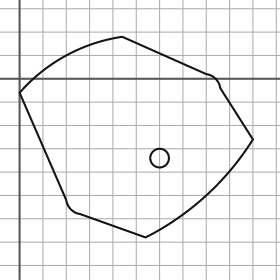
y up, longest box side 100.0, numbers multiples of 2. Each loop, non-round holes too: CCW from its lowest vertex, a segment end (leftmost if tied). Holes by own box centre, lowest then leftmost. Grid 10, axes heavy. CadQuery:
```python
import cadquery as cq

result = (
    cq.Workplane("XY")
    .moveTo(54.0, -68.0)
    .threePointArc((80.0, -50.0), (100.0, -26.0))
    .lineTo(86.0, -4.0)
    .threePointArc((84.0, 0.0), (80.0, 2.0))
    .lineTo(44.0, 18.0)
    .threePointArc((20.0, 10.0), (0.0, -6.0))
    .lineTo(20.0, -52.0)
    .threePointArc((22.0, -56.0), (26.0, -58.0))
    .close()
    .moveTo(60.0, -34.0)
    .circle(4.0)
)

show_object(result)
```